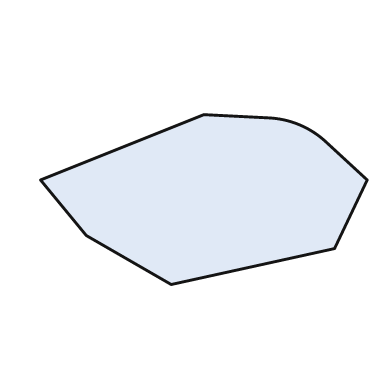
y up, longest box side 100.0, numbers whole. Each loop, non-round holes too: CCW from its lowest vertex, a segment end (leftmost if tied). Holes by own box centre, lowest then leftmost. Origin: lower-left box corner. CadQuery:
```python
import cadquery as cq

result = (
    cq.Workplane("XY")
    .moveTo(40.0, 0.0)
    .lineTo(90.0, 11.0)
    .lineTo(100.0, 32.0)
    .lineTo(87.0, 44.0)
    .threePointArc((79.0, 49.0), (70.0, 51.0))
    .lineTo(50.0, 52.0)
    .lineTo(0.0, 32.0)
    .lineTo(14.0, 15.0)
    .close()
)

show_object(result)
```